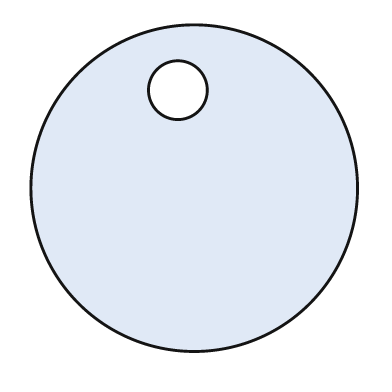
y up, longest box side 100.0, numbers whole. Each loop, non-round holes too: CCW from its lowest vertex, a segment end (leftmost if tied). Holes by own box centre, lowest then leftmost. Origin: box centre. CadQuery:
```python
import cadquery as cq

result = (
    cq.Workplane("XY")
    .moveTo(0.0, 0.0)
    .circle(50.0)
    .moveTo(-5.0, 30.0)
    .circle(9.0)
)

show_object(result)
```